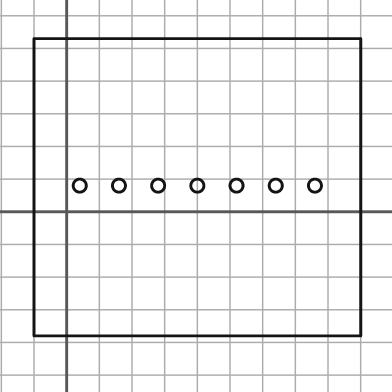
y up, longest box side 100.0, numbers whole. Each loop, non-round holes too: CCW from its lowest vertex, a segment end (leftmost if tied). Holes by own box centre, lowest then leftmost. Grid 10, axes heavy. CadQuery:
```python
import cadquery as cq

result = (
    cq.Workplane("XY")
    .moveTo(-10.0, -38.0)
    .lineTo(90.0, -38.0)
    .lineTo(90.0, 53.0)
    .lineTo(-10.0, 53.0)
    .close()
    .moveTo(4.0, 8.0)
    .circle(2.0)
    .moveTo(16.0, 8.0)
    .circle(2.0)
    .moveTo(28.0, 8.0)
    .circle(2.0)
    .moveTo(40.0, 8.0)
    .circle(2.0)
    .moveTo(52.0, 8.0)
    .circle(2.0)
    .moveTo(64.0, 8.0)
    .circle(2.0)
    .moveTo(76.0, 8.0)
    .circle(2.0)
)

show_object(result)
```